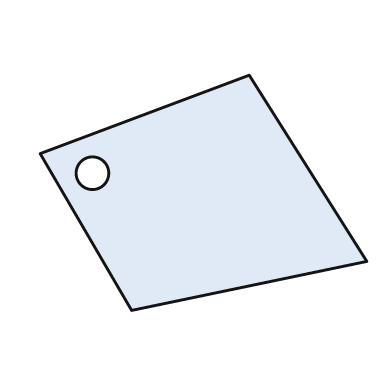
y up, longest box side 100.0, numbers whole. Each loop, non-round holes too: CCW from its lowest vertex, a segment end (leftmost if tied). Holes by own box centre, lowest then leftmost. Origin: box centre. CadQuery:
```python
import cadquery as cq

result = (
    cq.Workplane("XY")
    .moveTo(-22.0, -36.0)
    .lineTo(50.0, -21.0)
    .lineTo(14.0, 36.0)
    .lineTo(-50.0, 12.0)
    .close()
    .moveTo(-34.0, 6.0)
    .circle(5.0)
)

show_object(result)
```